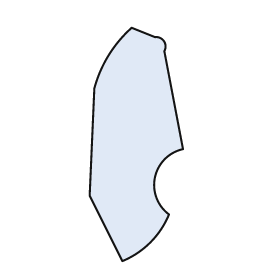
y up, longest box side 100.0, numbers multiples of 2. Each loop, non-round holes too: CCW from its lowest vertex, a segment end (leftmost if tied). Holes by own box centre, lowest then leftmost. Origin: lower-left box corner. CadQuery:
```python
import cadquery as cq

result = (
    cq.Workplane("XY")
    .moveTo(14.0, 0.0)
    .threePointArc((26.0, 8.0), (34.0, 20.0))
    .threePointArc((28.0, 36.0), (40.0, 48.0))
    .lineTo(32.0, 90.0)
    .threePointArc((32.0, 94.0), (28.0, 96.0))
    .lineTo(18.0, 100.0)
    .threePointArc((8.0, 88.0), (2.0, 74.0))
    .lineTo(0.0, 28.0)
    .close()
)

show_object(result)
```